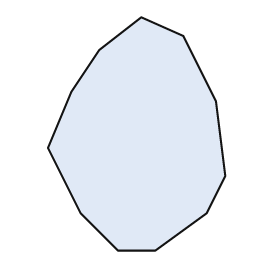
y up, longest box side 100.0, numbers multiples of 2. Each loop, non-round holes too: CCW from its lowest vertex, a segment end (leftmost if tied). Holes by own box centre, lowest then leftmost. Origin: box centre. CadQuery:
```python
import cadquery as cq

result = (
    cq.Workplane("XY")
    .moveTo(-8.0, -50.0)
    .lineTo(8.0, -50.0)
    .lineTo(30.0, -34.0)
    .lineTo(38.0, -18.0)
    .lineTo(34.0, 14.0)
    .lineTo(20.0, 42.0)
    .lineTo(2.0, 50.0)
    .lineTo(-16.0, 36.0)
    .lineTo(-28.0, 18.0)
    .lineTo(-38.0, -6.0)
    .lineTo(-24.0, -34.0)
    .close()
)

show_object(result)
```